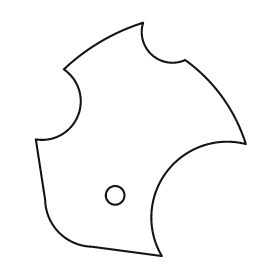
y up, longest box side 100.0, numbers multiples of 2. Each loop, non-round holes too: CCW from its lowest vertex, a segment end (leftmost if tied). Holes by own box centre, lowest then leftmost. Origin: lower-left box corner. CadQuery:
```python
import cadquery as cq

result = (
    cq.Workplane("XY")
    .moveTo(54.0, 0.0)
    .threePointArc((56.0, 36.0), (90.0, 48.0))
    .threePointArc((80.0, 68.0), (64.0, 84.0))
    .threePointArc((50.0, 86.0), (46.0, 100.0))
    .threePointArc((28.0, 92.0), (12.0, 80.0))
    .threePointArc((18.0, 60.0), (0.0, 50.0))
    .lineTo(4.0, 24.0)
    .threePointArc((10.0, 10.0), (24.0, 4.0))
    .close()
    .moveTo(34.0, 26.0)
    .circle(4.0)
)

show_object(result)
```